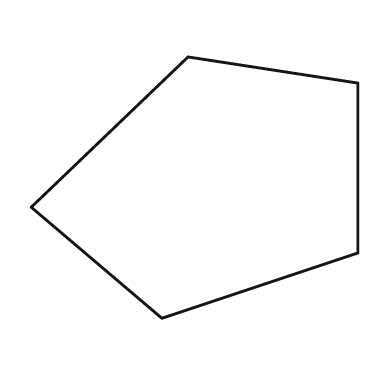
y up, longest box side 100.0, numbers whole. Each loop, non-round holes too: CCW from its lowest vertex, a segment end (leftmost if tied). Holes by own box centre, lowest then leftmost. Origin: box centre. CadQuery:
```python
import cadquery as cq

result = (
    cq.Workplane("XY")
    .moveTo(-10.0, -40.0)
    .lineTo(50.0, -20.0)
    .lineTo(50.0, 32.0)
    .lineTo(-2.0, 40.0)
    .lineTo(-50.0, -6.0)
    .close()
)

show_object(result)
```